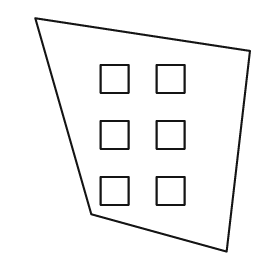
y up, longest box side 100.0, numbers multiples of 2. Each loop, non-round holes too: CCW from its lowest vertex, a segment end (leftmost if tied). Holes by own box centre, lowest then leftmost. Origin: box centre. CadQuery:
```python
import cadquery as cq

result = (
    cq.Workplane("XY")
    .moveTo(36.0, -50.0)
    .lineTo(46.0, 36.0)
    .lineTo(-46.0, 50.0)
    .lineTo(-22.0, -34.0)
    .close()
    .moveTo(-18.0, -30.0)
    .lineTo(-6.0, -30.0)
    .lineTo(-6.0, -18.0)
    .lineTo(-18.0, -18.0)
    .close()
    .moveTo(6.0, -30.0)
    .lineTo(18.0, -30.0)
    .lineTo(18.0, -18.0)
    .lineTo(6.0, -18.0)
    .close()
    .moveTo(-18.0, -6.0)
    .lineTo(-6.0, -6.0)
    .lineTo(-6.0, 6.0)
    .lineTo(-18.0, 6.0)
    .close()
    .moveTo(6.0, -6.0)
    .lineTo(18.0, -6.0)
    .lineTo(18.0, 6.0)
    .lineTo(6.0, 6.0)
    .close()
    .moveTo(-18.0, 18.0)
    .lineTo(-6.0, 18.0)
    .lineTo(-6.0, 30.0)
    .lineTo(-18.0, 30.0)
    .close()
    .moveTo(6.0, 18.0)
    .lineTo(18.0, 18.0)
    .lineTo(18.0, 30.0)
    .lineTo(6.0, 30.0)
    .close()
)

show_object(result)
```